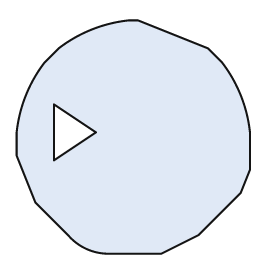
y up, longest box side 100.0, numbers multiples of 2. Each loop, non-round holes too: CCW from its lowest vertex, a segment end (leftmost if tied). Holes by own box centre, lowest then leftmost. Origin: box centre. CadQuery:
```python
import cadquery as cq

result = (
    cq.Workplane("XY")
    .moveTo(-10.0, -50.0)
    .lineTo(12.0, -50.0)
    .lineTo(28.0, -42.0)
    .lineTo(46.0, -24.0)
    .lineTo(50.0, -14.0)
    .lineTo(50.0, 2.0)
    .threePointArc((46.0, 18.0), (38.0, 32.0))
    .lineTo(32.0, 38.0)
    .lineTo(2.0, 50.0)
    .lineTo(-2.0, 50.0)
    .threePointArc((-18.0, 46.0), (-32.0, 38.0))
    .lineTo(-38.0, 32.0)
    .threePointArc((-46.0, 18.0), (-50.0, 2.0))
    .lineTo(-50.0, -8.0)
    .lineTo(-42.0, -28.0)
    .lineTo(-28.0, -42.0)
    .threePointArc((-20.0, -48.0), (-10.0, -50.0))
    .close()
    .moveTo(-34.0, -10.0)
    .lineTo(-16.0, 2.0)
    .lineTo(-34.0, 14.0)
    .close()
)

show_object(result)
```